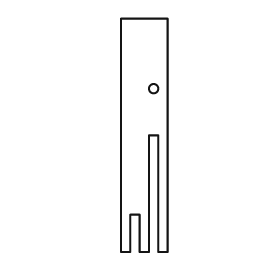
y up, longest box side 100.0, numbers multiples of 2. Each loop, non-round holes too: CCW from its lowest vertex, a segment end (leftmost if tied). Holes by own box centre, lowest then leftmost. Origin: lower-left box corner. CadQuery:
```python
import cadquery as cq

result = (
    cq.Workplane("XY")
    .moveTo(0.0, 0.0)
    .lineTo(4.0, 0.0)
    .lineTo(4.0, 16.0)
    .lineTo(8.0, 16.0)
    .lineTo(8.0, 0.0)
    .lineTo(12.0, 0.0)
    .lineTo(12.0, 50.0)
    .lineTo(16.0, 50.0)
    .lineTo(16.0, 0.0)
    .lineTo(20.0, 0.0)
    .lineTo(20.0, 100.0)
    .lineTo(0.0, 100.0)
    .close()
    .moveTo(14.0, 70.0)
    .circle(2.0)
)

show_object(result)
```